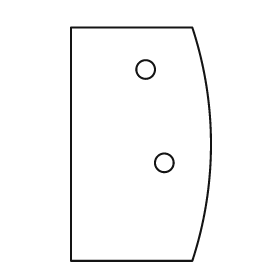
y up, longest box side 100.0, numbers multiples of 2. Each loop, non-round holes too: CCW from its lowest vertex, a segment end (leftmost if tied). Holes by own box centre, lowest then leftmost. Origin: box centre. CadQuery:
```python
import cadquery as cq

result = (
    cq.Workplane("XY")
    .moveTo(-30.0, -50.0)
    .lineTo(22.0, -50.0)
    .threePointArc((30.0, 0.0), (22.0, 50.0))
    .lineTo(-30.0, 50.0)
    .close()
    .moveTo(10.0, -8.0)
    .circle(4.0)
    .moveTo(2.0, 32.0)
    .circle(4.0)
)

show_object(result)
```